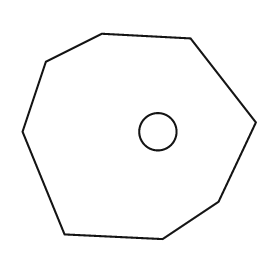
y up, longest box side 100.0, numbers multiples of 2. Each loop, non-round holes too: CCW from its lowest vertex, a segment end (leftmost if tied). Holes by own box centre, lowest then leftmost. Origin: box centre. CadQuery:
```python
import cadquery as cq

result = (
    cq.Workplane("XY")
    .moveTo(10.0, -44.0)
    .lineTo(34.0, -28.0)
    .lineTo(50.0, 6.0)
    .lineTo(22.0, 42.0)
    .lineTo(-16.0, 44.0)
    .lineTo(-40.0, 32.0)
    .lineTo(-50.0, 2.0)
    .lineTo(-32.0, -42.0)
    .close()
    .moveTo(8.0, 2.0)
    .circle(8.0)
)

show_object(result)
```